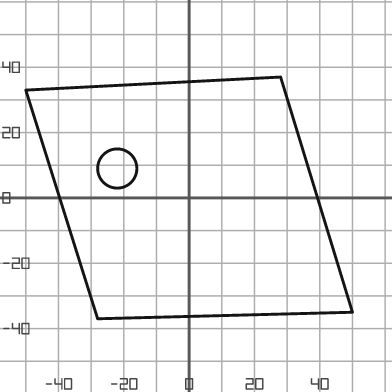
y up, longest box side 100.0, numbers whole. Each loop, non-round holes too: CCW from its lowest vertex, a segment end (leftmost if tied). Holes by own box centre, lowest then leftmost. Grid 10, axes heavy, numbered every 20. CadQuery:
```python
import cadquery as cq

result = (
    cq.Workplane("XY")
    .moveTo(-28.0, -37.0)
    .lineTo(50.0, -35.0)
    .lineTo(28.0, 37.0)
    .lineTo(-50.0, 33.0)
    .close()
    .moveTo(-22.0, 9.0)
    .circle(6.0)
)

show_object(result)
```